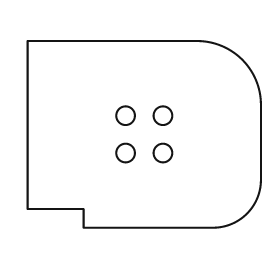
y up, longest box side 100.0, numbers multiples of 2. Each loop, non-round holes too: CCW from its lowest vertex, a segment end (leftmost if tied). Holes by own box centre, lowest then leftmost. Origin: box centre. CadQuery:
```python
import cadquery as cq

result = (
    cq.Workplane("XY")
    .moveTo(-26.0, -40.0)
    .lineTo(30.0, -40.0)
    .threePointArc((44.0, -34.0), (50.0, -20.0))
    .lineTo(50.0, 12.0)
    .threePointArc((42.0, 32.0), (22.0, 40.0))
    .lineTo(-50.0, 40.0)
    .lineTo(-50.0, -32.0)
    .lineTo(-26.0, -32.0)
    .close()
    .moveTo(-8.0, -8.0)
    .circle(4.0)
    .moveTo(8.0, -8.0)
    .circle(4.0)
    .moveTo(-8.0, 8.0)
    .circle(4.0)
    .moveTo(8.0, 8.0)
    .circle(4.0)
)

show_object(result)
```